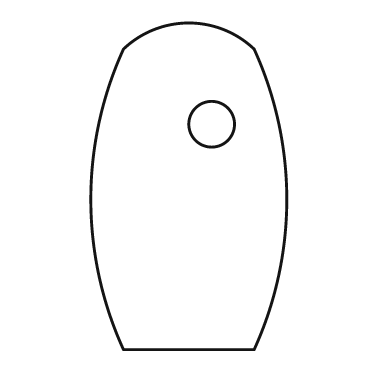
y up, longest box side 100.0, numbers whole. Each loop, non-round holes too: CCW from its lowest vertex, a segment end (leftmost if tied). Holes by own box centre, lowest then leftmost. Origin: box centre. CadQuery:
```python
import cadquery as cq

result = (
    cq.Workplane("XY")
    .moveTo(-20.0, -50.0)
    .lineTo(20.0, -50.0)
    .threePointArc((30.0, -4.0), (20.0, 42.0))
    .threePointArc((0.0, 50.0), (-20.0, 42.0))
    .threePointArc((-30.0, -4.0), (-20.0, -50.0))
    .close()
    .moveTo(7.0, 19.0)
    .circle(7.0)
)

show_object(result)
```